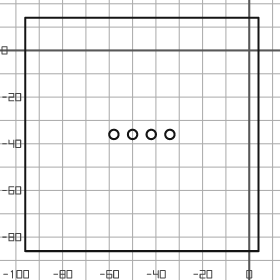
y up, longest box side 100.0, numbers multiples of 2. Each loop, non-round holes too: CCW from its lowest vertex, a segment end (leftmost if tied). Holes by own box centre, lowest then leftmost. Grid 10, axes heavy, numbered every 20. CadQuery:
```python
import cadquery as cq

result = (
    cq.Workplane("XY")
    .moveTo(-96.0, -86.0)
    .lineTo(4.0, -86.0)
    .lineTo(4.0, 14.0)
    .lineTo(-96.0, 14.0)
    .close()
    .moveTo(-58.0, -36.0)
    .circle(2.0)
    .moveTo(-50.0, -36.0)
    .circle(2.0)
    .moveTo(-42.0, -36.0)
    .circle(2.0)
    .moveTo(-34.0, -36.0)
    .circle(2.0)
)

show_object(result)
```